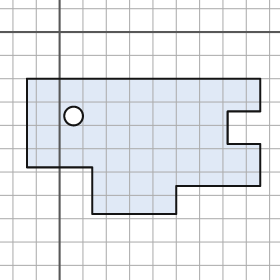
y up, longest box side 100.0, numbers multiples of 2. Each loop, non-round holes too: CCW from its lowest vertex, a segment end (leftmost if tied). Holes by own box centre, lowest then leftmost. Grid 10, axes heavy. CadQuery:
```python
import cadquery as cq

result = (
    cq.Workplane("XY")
    .moveTo(14.0, -78.0)
    .lineTo(50.0, -78.0)
    .lineTo(50.0, -66.0)
    .lineTo(86.0, -66.0)
    .lineTo(86.0, -48.0)
    .lineTo(72.0, -48.0)
    .lineTo(72.0, -34.0)
    .lineTo(86.0, -34.0)
    .lineTo(86.0, -20.0)
    .lineTo(-14.0, -20.0)
    .lineTo(-14.0, -58.0)
    .lineTo(14.0, -58.0)
    .close()
    .moveTo(6.0, -36.0)
    .circle(4.0)
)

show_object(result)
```